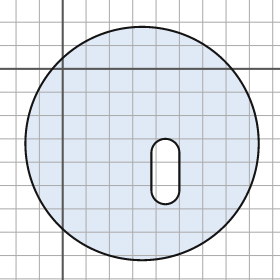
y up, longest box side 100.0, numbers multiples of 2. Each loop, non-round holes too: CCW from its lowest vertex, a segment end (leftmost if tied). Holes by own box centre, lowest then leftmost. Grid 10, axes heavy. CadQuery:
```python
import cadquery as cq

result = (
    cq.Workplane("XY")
    .moveTo(34.0, -32.0)
    .circle(50.0)
    .moveTo(38.0, -52.0)
    .threePointArc((44.0, -58.0), (50.0, -52.0))
    .lineTo(50.0, -36.0)
    .threePointArc((44.0, -30.0), (38.0, -36.0))
    .close()
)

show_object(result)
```